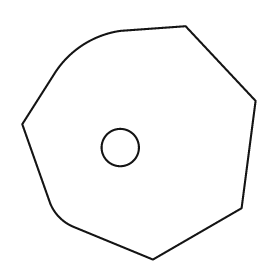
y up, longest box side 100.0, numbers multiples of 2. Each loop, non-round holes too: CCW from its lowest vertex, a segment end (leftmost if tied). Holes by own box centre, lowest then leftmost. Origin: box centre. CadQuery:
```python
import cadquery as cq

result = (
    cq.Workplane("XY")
    .moveTo(6.0, -50.0)
    .lineTo(44.0, -28.0)
    .lineTo(50.0, 18.0)
    .lineTo(20.0, 50.0)
    .lineTo(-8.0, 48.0)
    .threePointArc((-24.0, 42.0), (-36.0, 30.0))
    .lineTo(-50.0, 8.0)
    .lineTo(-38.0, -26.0)
    .threePointArc((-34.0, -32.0), (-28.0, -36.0))
    .close()
    .moveTo(-8.0, -2.0)
    .circle(8.0)
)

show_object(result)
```